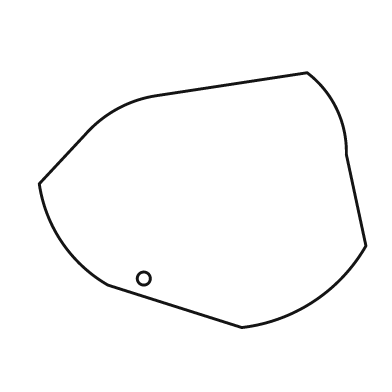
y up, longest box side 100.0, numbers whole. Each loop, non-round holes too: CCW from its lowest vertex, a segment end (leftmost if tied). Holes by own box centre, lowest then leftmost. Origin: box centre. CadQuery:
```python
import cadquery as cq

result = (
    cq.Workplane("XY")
    .moveTo(12.0, -39.0)
    .threePointArc((34.0, -31.0), (50.0, -14.0))
    .lineTo(44.0, 14.0)
    .threePointArc((41.0, 28.0), (32.0, 39.0))
    .lineTo(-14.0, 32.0)
    .threePointArc((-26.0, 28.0), (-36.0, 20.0))
    .lineTo(-50.0, 5.0)
    .threePointArc((-43.0, -13.0), (-29.0, -26.0))
    .close()
    .moveTo(-18.0, -24.0)
    .circle(2.0)
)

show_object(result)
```